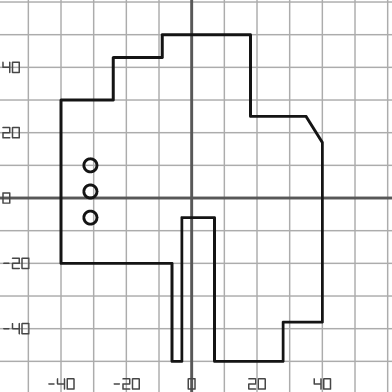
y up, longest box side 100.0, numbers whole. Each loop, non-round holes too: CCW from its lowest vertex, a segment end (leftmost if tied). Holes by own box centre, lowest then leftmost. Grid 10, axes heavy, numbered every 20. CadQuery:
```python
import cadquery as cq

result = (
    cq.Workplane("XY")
    .moveTo(-6.0, -50.0)
    .lineTo(-3.0, -50.0)
    .lineTo(-3.0, -6.0)
    .lineTo(7.0, -6.0)
    .lineTo(7.0, -50.0)
    .lineTo(28.0, -50.0)
    .lineTo(28.0, -38.0)
    .lineTo(40.0, -38.0)
    .lineTo(40.0, 17.0)
    .lineTo(35.0, 25.0)
    .lineTo(18.0, 25.0)
    .lineTo(18.0, 50.0)
    .lineTo(-9.0, 50.0)
    .lineTo(-9.0, 43.0)
    .lineTo(-24.0, 43.0)
    .lineTo(-24.0, 30.0)
    .lineTo(-40.0, 30.0)
    .lineTo(-40.0, -20.0)
    .lineTo(-6.0, -20.0)
    .close()
    .moveTo(-31.0, -6.0)
    .circle(2.0)
    .moveTo(-31.0, 2.0)
    .circle(2.0)
    .moveTo(-31.0, 10.0)
    .circle(2.0)
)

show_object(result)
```